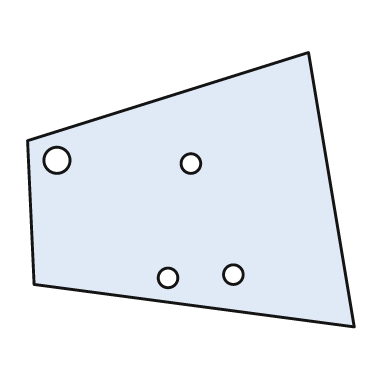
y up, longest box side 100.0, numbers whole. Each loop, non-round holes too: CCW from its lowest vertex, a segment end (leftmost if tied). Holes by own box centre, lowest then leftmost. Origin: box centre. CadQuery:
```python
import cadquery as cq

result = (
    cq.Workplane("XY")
    .moveTo(50.0, -42.0)
    .lineTo(36.0, 42.0)
    .lineTo(-50.0, 15.0)
    .lineTo(-48.0, -29.0)
    .close()
    .moveTo(-7.0, -27.0)
    .circle(3.0)
    .moveTo(13.0, -26.0)
    .circle(3.0)
    .moveTo(0.0, 8.0)
    .circle(3.0)
    .moveTo(-41.0, 9.0)
    .circle(4.0)
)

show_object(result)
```